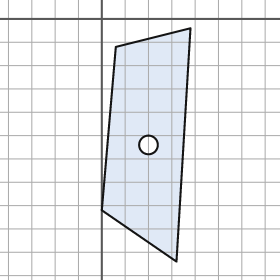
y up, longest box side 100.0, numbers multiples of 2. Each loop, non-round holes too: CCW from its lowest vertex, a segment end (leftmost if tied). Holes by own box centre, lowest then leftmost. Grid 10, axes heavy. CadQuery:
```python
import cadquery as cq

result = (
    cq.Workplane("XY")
    .moveTo(32.0, -104.0)
    .lineTo(38.0, -4.0)
    .lineTo(6.0, -12.0)
    .lineTo(0.0, -82.0)
    .close()
    .moveTo(20.0, -54.0)
    .circle(4.0)
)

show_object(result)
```